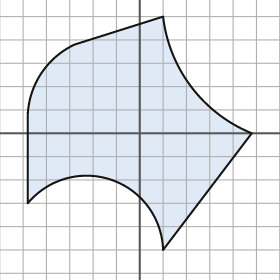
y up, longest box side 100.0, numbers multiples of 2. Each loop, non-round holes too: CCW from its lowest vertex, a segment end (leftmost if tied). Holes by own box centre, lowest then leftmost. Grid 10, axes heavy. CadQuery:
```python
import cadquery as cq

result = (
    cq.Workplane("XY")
    .moveTo(10.0, -50.0)
    .lineTo(48.0, 0.0)
    .threePointArc((22.0, 20.0), (10.0, 50.0))
    .lineTo(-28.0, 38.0)
    .threePointArc((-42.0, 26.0), (-48.0, 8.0))
    .lineTo(-48.0, -30.0)
    .threePointArc((-12.0, -20.0), (10.0, -50.0))
    .close()
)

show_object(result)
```